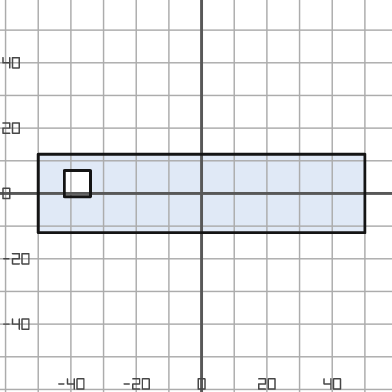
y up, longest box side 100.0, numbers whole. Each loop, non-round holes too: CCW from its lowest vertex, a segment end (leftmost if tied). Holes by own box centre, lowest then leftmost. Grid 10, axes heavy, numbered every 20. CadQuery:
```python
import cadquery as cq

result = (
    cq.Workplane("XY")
    .moveTo(-50.0, -12.0)
    .lineTo(50.0, -12.0)
    .lineTo(50.0, 12.0)
    .lineTo(-50.0, 12.0)
    .close()
    .moveTo(-42.0, -1.0)
    .lineTo(-34.0, -1.0)
    .lineTo(-34.0, 7.0)
    .lineTo(-42.0, 7.0)
    .close()
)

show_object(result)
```